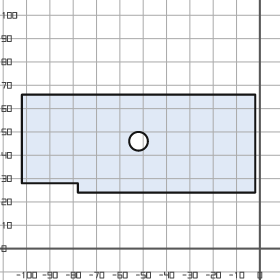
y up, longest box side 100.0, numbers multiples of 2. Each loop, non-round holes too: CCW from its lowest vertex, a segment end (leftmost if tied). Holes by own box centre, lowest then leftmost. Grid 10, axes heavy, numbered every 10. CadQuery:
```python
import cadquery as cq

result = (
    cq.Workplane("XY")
    .moveTo(-78.0, 24.0)
    .lineTo(-2.0, 24.0)
    .lineTo(-2.0, 66.0)
    .lineTo(-102.0, 66.0)
    .lineTo(-102.0, 28.0)
    .lineTo(-78.0, 28.0)
    .close()
    .moveTo(-52.0, 46.0)
    .circle(4.0)
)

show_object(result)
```